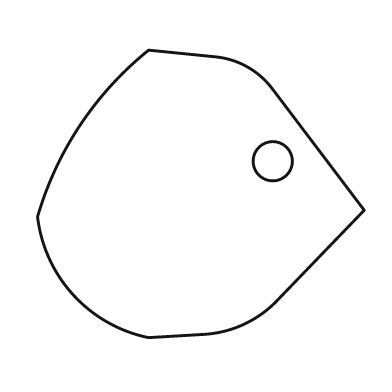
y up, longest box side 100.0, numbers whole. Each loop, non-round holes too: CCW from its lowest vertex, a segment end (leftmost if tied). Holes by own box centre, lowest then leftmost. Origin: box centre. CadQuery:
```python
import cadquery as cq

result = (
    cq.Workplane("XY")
    .moveTo(-16.0, -44.0)
    .lineTo(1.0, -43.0)
    .threePointArc((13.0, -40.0), (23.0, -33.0))
    .lineTo(50.0, -5.0)
    .lineTo(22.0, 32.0)
    .threePointArc((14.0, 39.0), (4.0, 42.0))
    .lineTo(-16.0, 44.0)
    .threePointArc((-37.0, 21.0), (-50.0, -7.0))
    .threePointArc((-39.0, -31.0), (-16.0, -44.0))
    .close()
    .moveTo(22.0, 10.0)
    .circle(6.0)
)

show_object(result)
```